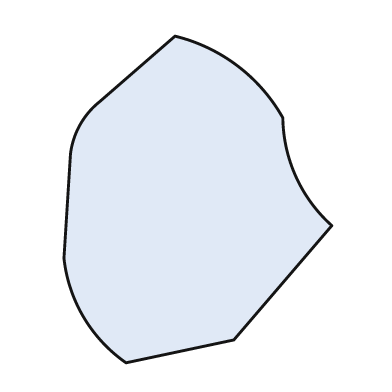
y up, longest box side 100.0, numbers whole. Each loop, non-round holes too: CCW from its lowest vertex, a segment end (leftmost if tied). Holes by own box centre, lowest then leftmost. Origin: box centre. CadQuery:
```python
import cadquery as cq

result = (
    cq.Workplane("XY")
    .moveTo(-22.0, -50.0)
    .lineTo(11.0, -43.0)
    .lineTo(41.0, -8.0)
    .threePointArc((30.0, 7.0), (26.0, 25.0))
    .threePointArc((12.0, 41.0), (-7.0, 50.0))
    .lineTo(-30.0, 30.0)
    .threePointArc((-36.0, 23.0), (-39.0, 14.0))
    .lineTo(-41.0, -18.0)
    .threePointArc((-35.0, -36.0), (-22.0, -50.0))
    .close()
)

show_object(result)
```